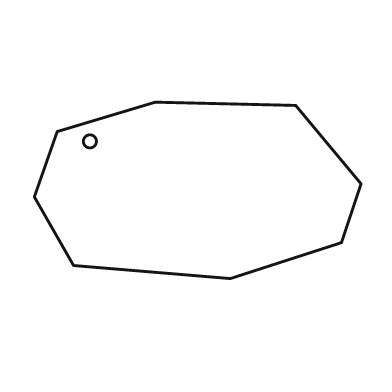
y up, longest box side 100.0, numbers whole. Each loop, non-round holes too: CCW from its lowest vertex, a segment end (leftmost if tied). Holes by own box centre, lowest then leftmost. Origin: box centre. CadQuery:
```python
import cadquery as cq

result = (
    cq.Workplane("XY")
    .moveTo(10.0, -27.0)
    .lineTo(44.0, -16.0)
    .lineTo(50.0, 2.0)
    .lineTo(30.0, 26.0)
    .lineTo(-13.0, 27.0)
    .lineTo(-43.0, 18.0)
    .lineTo(-50.0, -2.0)
    .lineTo(-38.0, -23.0)
    .close()
    .moveTo(-33.0, 15.0)
    .circle(2.0)
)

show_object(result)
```